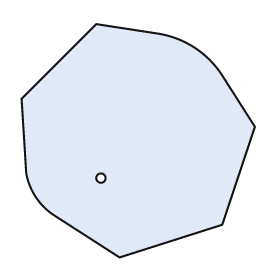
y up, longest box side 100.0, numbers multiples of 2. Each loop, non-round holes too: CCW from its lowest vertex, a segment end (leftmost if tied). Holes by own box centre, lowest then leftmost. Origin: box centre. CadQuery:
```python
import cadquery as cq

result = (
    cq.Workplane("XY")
    .moveTo(-8.0, -50.0)
    .lineTo(36.0, -36.0)
    .lineTo(50.0, 6.0)
    .lineTo(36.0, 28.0)
    .threePointArc((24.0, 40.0), (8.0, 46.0))
    .lineTo(-18.0, 50.0)
    .lineTo(-50.0, 18.0)
    .lineTo(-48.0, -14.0)
    .threePointArc((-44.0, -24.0), (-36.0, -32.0))
    .close()
    .moveTo(-16.0, -16.0)
    .circle(2.0)
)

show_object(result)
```